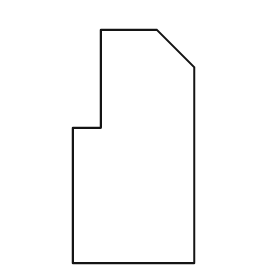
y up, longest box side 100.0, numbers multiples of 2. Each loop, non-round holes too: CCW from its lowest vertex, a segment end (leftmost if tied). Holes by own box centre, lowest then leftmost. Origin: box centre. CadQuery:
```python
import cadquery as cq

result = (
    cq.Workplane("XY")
    .moveTo(-26.0, -50.0)
    .lineTo(26.0, -50.0)
    .lineTo(26.0, 34.0)
    .lineTo(10.0, 50.0)
    .lineTo(-14.0, 50.0)
    .lineTo(-14.0, 8.0)
    .lineTo(-26.0, 8.0)
    .close()
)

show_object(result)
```